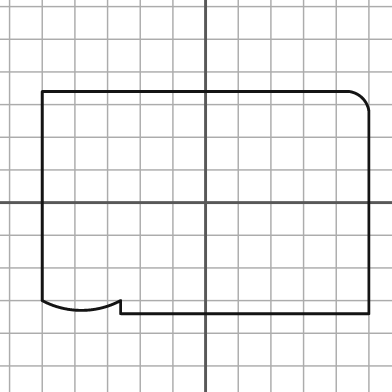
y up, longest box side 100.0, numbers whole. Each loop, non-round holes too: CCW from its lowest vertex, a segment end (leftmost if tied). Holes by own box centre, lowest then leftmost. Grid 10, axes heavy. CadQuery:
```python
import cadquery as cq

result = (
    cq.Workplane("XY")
    .moveTo(-26.0, -34.0)
    .lineTo(50.0, -34.0)
    .lineTo(50.0, 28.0)
    .threePointArc((48.0, 32.0), (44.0, 34.0))
    .lineTo(-50.0, 34.0)
    .lineTo(-50.0, -30.0)
    .threePointArc((-38.0, -33.0), (-26.0, -30.0))
    .close()
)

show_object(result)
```